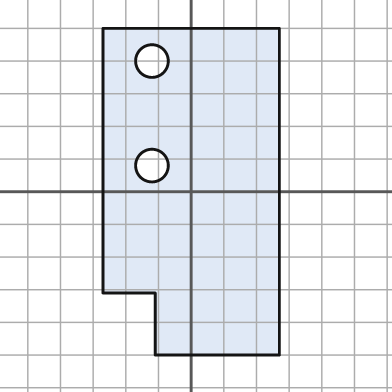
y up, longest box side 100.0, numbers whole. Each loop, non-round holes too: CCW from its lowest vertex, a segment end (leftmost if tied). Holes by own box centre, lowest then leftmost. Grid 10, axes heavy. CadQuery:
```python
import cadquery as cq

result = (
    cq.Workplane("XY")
    .moveTo(-11.0, -50.0)
    .lineTo(27.0, -50.0)
    .lineTo(27.0, 50.0)
    .lineTo(-27.0, 50.0)
    .lineTo(-27.0, -31.0)
    .lineTo(-11.0, -31.0)
    .close()
    .moveTo(-12.0, 8.0)
    .circle(5.0)
    .moveTo(-12.0, 40.0)
    .circle(5.0)
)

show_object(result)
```